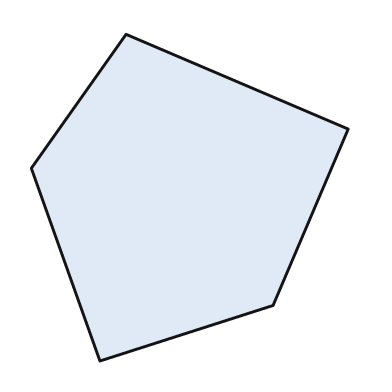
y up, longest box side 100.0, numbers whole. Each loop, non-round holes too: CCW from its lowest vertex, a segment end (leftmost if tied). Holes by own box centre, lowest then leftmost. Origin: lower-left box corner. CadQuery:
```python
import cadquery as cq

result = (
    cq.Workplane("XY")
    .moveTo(21.0, 0.0)
    .lineTo(74.0, 17.0)
    .lineTo(97.0, 71.0)
    .lineTo(29.0, 100.0)
    .lineTo(0.0, 59.0)
    .close()
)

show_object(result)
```